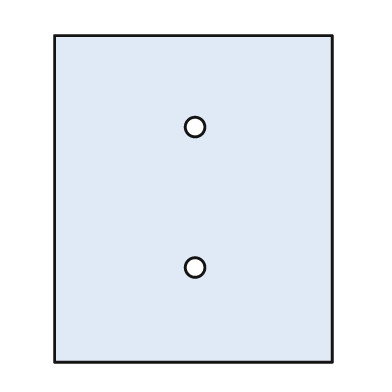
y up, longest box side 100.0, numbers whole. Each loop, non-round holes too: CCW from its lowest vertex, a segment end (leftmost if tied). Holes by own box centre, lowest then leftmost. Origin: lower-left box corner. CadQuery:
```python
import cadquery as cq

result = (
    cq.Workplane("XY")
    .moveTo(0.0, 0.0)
    .lineTo(85.0, 0.0)
    .lineTo(85.0, 100.0)
    .lineTo(0.0, 100.0)
    .close()
    .moveTo(43.0, 29.0)
    .circle(3.0)
    .moveTo(43.0, 72.0)
    .circle(3.0)
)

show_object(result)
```